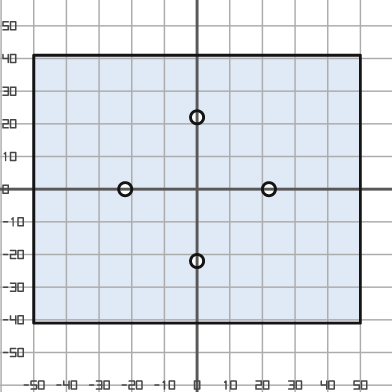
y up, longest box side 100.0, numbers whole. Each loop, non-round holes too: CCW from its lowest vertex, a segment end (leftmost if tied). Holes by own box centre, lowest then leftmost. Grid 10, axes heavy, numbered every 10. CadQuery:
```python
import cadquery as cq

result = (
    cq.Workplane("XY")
    .moveTo(-50.0, -41.0)
    .lineTo(50.0, -41.0)
    .lineTo(50.0, 41.0)
    .lineTo(-50.0, 41.0)
    .close()
    .moveTo(0.0, -22.0)
    .circle(2.0)
    .moveTo(-22.0, 0.0)
    .circle(2.0)
    .moveTo(22.0, 0.0)
    .circle(2.0)
    .moveTo(0.0, 22.0)
    .circle(2.0)
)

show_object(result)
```